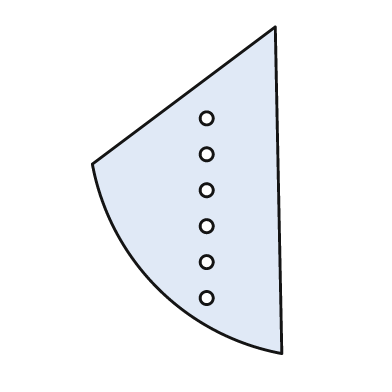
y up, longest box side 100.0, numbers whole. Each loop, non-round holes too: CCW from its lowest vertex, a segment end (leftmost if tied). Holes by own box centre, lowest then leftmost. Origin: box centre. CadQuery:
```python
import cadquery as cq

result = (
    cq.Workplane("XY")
    .moveTo(29.0, -50.0)
    .lineTo(27.0, 50.0)
    .lineTo(-29.0, 8.0)
    .threePointArc((-9.0, -30.0), (29.0, -50.0))
    .close()
    .moveTo(6.0, -33.0)
    .circle(2.0)
    .moveTo(6.0, -22.0)
    .circle(2.0)
    .moveTo(6.0, -11.0)
    .circle(2.0)
    .moveTo(6.0, 0.0)
    .circle(2.0)
    .moveTo(6.0, 11.0)
    .circle(2.0)
    .moveTo(6.0, 22.0)
    .circle(2.0)
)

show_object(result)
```